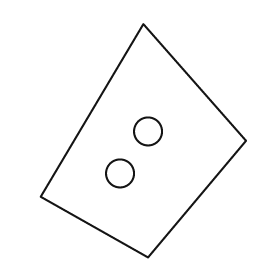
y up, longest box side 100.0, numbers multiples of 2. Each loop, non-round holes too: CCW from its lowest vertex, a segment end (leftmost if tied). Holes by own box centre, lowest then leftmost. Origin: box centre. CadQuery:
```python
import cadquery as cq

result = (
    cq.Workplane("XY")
    .moveTo(2.0, -50.0)
    .lineTo(44.0, 0.0)
    .lineTo(0.0, 50.0)
    .lineTo(-44.0, -24.0)
    .close()
    .moveTo(-10.0, -14.0)
    .circle(6.0)
    .moveTo(2.0, 4.0)
    .circle(6.0)
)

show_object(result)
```